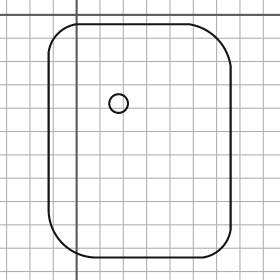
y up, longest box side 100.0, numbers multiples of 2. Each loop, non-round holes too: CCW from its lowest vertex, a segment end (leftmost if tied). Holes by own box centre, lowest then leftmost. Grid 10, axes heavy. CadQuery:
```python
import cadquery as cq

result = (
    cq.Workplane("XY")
    .moveTo(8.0, -104.0)
    .lineTo(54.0, -104.0)
    .threePointArc((62.0, -100.0), (66.0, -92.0))
    .lineTo(66.0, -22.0)
    .threePointArc((60.0, -10.0), (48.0, -4.0))
    .lineTo(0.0, -4.0)
    .threePointArc((-8.0, -8.0), (-12.0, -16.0))
    .lineTo(-12.0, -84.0)
    .threePointArc((-6.0, -98.0), (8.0, -104.0))
    .close()
    .moveTo(18.0, -38.0)
    .circle(4.0)
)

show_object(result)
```